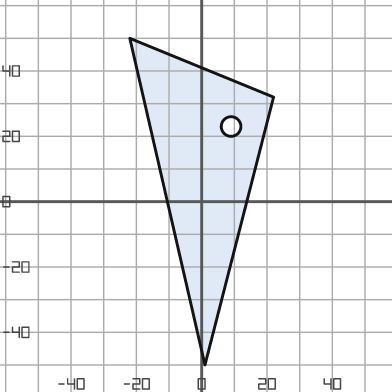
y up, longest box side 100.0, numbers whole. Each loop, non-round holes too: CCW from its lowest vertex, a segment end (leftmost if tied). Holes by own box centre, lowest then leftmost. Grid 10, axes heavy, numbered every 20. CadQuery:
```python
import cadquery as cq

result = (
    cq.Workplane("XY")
    .moveTo(1.0, -50.0)
    .lineTo(22.0, 32.0)
    .lineTo(-22.0, 50.0)
    .close()
    .moveTo(9.0, 23.0)
    .circle(3.0)
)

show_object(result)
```